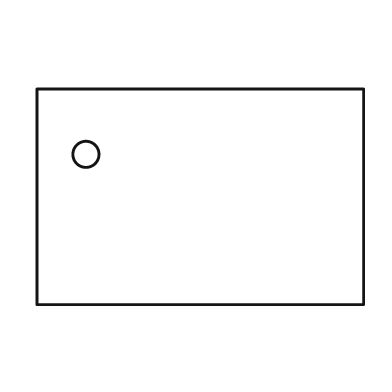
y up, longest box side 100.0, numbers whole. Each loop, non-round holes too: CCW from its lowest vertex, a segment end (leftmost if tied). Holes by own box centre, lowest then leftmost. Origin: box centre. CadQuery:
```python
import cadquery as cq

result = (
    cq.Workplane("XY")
    .moveTo(-50.0, -33.0)
    .lineTo(50.0, -33.0)
    .lineTo(50.0, 33.0)
    .lineTo(-50.0, 33.0)
    .close()
    .moveTo(-35.0, 13.0)
    .circle(4.0)
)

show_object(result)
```